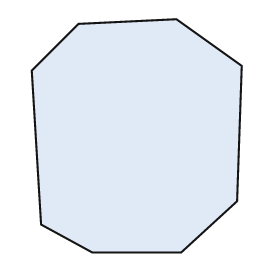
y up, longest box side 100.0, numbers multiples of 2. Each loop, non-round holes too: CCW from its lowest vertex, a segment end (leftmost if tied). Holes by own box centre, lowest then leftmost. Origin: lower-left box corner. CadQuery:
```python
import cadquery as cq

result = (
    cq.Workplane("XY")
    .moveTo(26.0, 0.0)
    .lineTo(64.0, 0.0)
    .lineTo(88.0, 22.0)
    .lineTo(90.0, 80.0)
    .lineTo(62.0, 100.0)
    .lineTo(20.0, 98.0)
    .lineTo(0.0, 78.0)
    .lineTo(4.0, 12.0)
    .close()
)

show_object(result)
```